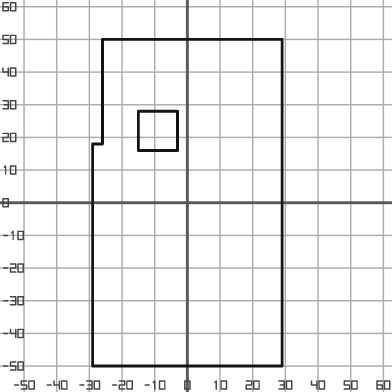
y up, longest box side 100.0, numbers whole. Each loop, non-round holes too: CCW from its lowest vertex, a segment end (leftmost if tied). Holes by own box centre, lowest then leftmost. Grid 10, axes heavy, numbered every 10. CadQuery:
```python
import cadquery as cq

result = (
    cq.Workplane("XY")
    .moveTo(-29.0, -50.0)
    .lineTo(29.0, -50.0)
    .lineTo(29.0, 50.0)
    .lineTo(-26.0, 50.0)
    .lineTo(-26.0, 18.0)
    .lineTo(-29.0, 18.0)
    .close()
    .moveTo(-15.0, 16.0)
    .lineTo(-3.0, 16.0)
    .lineTo(-3.0, 28.0)
    .lineTo(-15.0, 28.0)
    .close()
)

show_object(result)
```